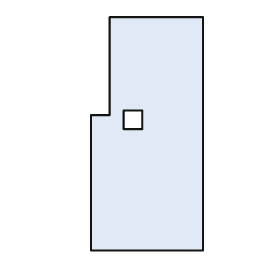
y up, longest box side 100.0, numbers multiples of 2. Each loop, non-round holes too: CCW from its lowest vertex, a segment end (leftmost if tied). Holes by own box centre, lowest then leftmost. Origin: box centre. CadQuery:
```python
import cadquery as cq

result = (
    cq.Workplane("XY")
    .moveTo(-24.0, -50.0)
    .lineTo(24.0, -50.0)
    .lineTo(24.0, 50.0)
    .lineTo(-16.0, 50.0)
    .lineTo(-16.0, 8.0)
    .lineTo(-24.0, 8.0)
    .close()
    .moveTo(-10.0, 2.0)
    .lineTo(-2.0, 2.0)
    .lineTo(-2.0, 10.0)
    .lineTo(-10.0, 10.0)
    .close()
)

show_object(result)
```